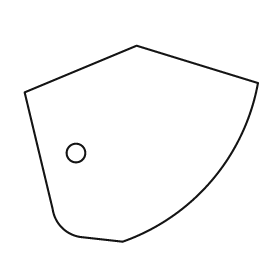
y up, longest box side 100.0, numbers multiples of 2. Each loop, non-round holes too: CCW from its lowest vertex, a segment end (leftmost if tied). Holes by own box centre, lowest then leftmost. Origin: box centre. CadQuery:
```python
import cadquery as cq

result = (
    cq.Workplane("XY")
    .moveTo(-8.0, -42.0)
    .threePointArc((30.0, -16.0), (50.0, 26.0))
    .lineTo(-2.0, 42.0)
    .lineTo(-50.0, 22.0)
    .lineTo(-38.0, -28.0)
    .threePointArc((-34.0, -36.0), (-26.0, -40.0))
    .close()
    .moveTo(-28.0, -4.0)
    .circle(4.0)
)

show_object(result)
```